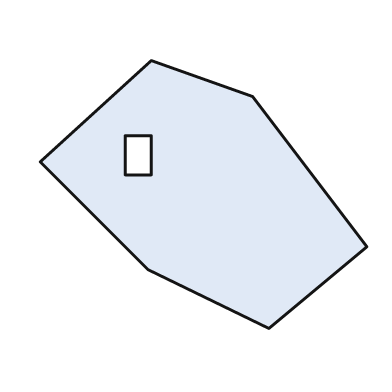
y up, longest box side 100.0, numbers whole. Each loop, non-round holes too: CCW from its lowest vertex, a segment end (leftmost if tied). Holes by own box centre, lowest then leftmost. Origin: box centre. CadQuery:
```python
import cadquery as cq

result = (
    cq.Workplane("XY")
    .moveTo(20.0, -41.0)
    .lineTo(50.0, -16.0)
    .lineTo(15.0, 30.0)
    .lineTo(-16.0, 41.0)
    .lineTo(-50.0, 10.0)
    .lineTo(-17.0, -23.0)
    .close()
    .moveTo(-24.0, 6.0)
    .lineTo(-16.0, 6.0)
    .lineTo(-16.0, 18.0)
    .lineTo(-24.0, 18.0)
    .close()
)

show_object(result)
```